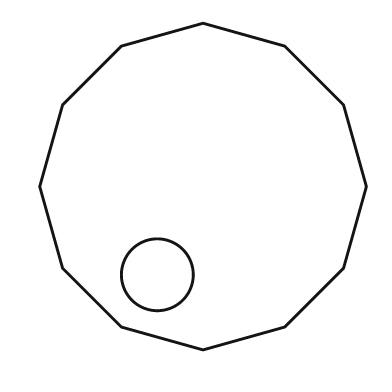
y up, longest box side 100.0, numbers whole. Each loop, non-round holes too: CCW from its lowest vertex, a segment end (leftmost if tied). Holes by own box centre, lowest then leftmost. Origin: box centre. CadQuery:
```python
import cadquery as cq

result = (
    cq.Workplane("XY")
    .moveTo(0.0, -50.0)
    .lineTo(25.0, -43.0)
    .lineTo(43.0, -25.0)
    .lineTo(50.0, 0.0)
    .lineTo(43.0, 25.0)
    .lineTo(25.0, 43.0)
    .lineTo(0.0, 50.0)
    .lineTo(-25.0, 43.0)
    .lineTo(-43.0, 25.0)
    .lineTo(-50.0, 0.0)
    .lineTo(-43.0, -25.0)
    .lineTo(-25.0, -43.0)
    .close()
    .moveTo(-14.0, -27.0)
    .circle(11.0)
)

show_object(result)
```